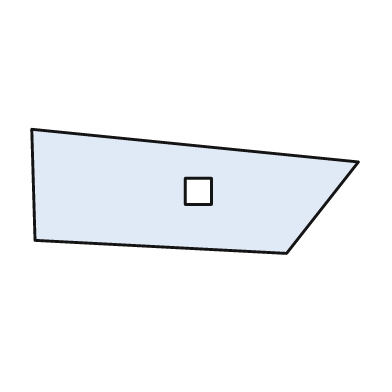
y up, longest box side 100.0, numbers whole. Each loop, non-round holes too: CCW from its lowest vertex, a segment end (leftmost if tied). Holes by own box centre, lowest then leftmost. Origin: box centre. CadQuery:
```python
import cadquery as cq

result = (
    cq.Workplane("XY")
    .moveTo(28.0, -19.0)
    .lineTo(50.0, 9.0)
    .lineTo(-50.0, 19.0)
    .lineTo(-49.0, -15.0)
    .close()
    .moveTo(-3.0, -4.0)
    .lineTo(5.0, -4.0)
    .lineTo(5.0, 4.0)
    .lineTo(-3.0, 4.0)
    .close()
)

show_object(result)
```